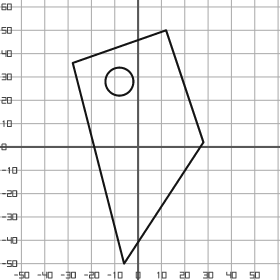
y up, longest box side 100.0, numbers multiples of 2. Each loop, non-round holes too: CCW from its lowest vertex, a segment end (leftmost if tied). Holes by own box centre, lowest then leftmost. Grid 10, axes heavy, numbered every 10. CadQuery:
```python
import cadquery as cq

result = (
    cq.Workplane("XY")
    .moveTo(-6.0, -50.0)
    .lineTo(28.0, 2.0)
    .lineTo(12.0, 50.0)
    .lineTo(-28.0, 36.0)
    .close()
    .moveTo(-8.0, 28.0)
    .circle(6.0)
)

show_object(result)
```